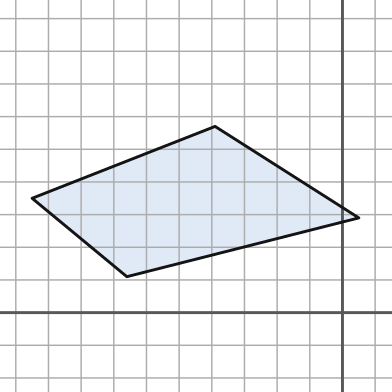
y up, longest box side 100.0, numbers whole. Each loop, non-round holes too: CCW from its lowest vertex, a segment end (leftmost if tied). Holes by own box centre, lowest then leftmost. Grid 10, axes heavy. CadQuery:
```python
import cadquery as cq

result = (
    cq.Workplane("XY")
    .moveTo(-66.0, 11.0)
    .lineTo(5.0, 29.0)
    .lineTo(-39.0, 57.0)
    .lineTo(-95.0, 35.0)
    .close()
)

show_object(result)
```